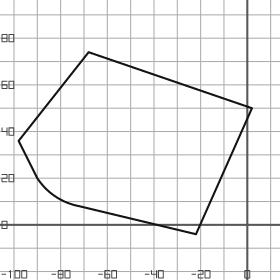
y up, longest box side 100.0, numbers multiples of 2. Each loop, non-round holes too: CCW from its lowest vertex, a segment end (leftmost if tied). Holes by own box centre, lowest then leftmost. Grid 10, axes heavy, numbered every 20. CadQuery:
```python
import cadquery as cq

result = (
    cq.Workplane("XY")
    .moveTo(-22.0, -4.0)
    .lineTo(2.0, 50.0)
    .lineTo(-68.0, 74.0)
    .lineTo(-98.0, 36.0)
    .lineTo(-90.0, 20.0)
    .threePointArc((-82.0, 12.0), (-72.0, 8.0))
    .close()
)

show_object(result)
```